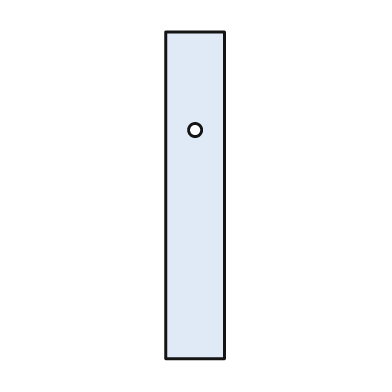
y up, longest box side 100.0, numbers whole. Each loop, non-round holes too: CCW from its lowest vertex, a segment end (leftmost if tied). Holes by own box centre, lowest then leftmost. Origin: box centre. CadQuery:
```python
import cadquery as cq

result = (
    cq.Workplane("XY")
    .moveTo(-9.0, -50.0)
    .lineTo(9.0, -50.0)
    .lineTo(9.0, 50.0)
    .lineTo(-9.0, 50.0)
    .close()
    .moveTo(0.0, 20.0)
    .circle(2.0)
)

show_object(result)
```